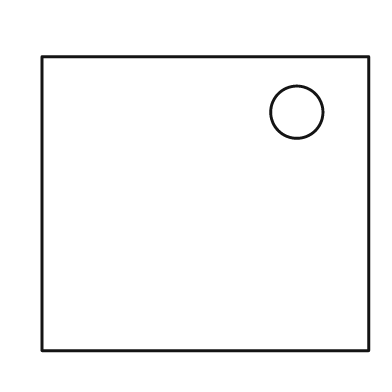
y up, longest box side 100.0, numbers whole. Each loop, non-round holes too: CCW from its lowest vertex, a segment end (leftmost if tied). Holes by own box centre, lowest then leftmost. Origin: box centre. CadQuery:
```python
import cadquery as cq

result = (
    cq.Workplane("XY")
    .moveTo(-50.0, -45.0)
    .lineTo(50.0, -45.0)
    .lineTo(50.0, 45.0)
    .lineTo(-50.0, 45.0)
    .close()
    .moveTo(28.0, 28.0)
    .circle(8.0)
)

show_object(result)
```